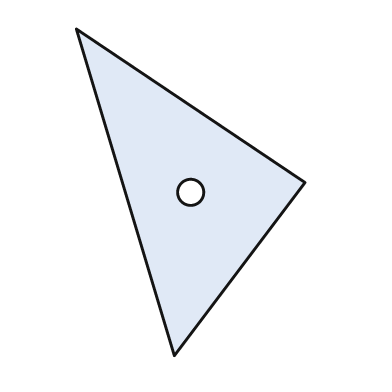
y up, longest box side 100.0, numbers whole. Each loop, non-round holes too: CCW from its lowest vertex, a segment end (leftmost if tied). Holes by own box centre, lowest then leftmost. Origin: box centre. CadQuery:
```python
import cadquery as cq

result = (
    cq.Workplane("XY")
    .moveTo(-5.0, -50.0)
    .lineTo(35.0, 3.0)
    .lineTo(-35.0, 50.0)
    .close()
    .moveTo(0.0, 0.0)
    .circle(4.0)
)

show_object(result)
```